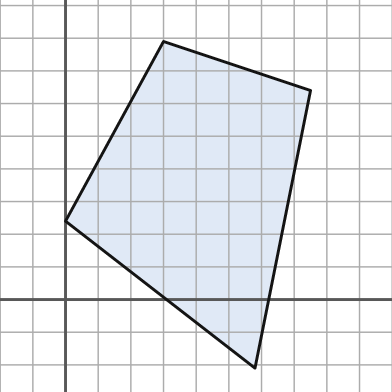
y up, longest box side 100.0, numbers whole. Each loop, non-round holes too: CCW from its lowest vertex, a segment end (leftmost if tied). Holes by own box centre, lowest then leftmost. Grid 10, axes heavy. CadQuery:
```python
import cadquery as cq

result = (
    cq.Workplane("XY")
    .moveTo(58.0, -21.0)
    .lineTo(75.0, 64.0)
    .lineTo(30.0, 79.0)
    .lineTo(0.0, 24.0)
    .close()
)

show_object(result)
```